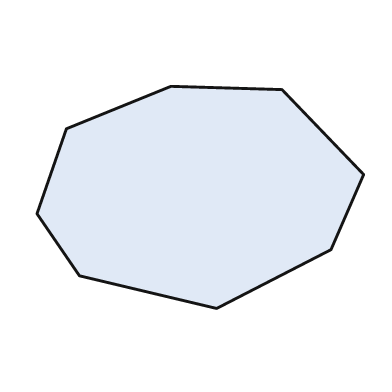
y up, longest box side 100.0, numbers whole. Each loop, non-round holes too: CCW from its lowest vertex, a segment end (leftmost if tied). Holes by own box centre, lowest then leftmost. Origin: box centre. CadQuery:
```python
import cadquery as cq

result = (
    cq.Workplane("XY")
    .moveTo(5.0, -34.0)
    .lineTo(40.0, -16.0)
    .lineTo(50.0, 7.0)
    .lineTo(25.0, 33.0)
    .lineTo(-9.0, 34.0)
    .lineTo(-41.0, 21.0)
    .lineTo(-50.0, -5.0)
    .lineTo(-37.0, -24.0)
    .close()
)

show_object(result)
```